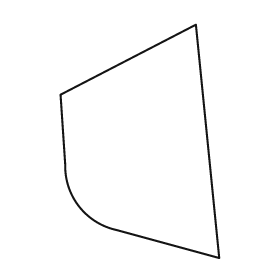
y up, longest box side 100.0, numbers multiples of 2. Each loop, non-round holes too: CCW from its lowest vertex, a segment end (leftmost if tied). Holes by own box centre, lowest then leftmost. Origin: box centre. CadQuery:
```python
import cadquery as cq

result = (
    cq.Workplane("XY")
    .moveTo(34.0, -50.0)
    .lineTo(24.0, 50.0)
    .lineTo(-34.0, 20.0)
    .lineTo(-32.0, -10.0)
    .threePointArc((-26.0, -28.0), (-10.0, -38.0))
    .close()
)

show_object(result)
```